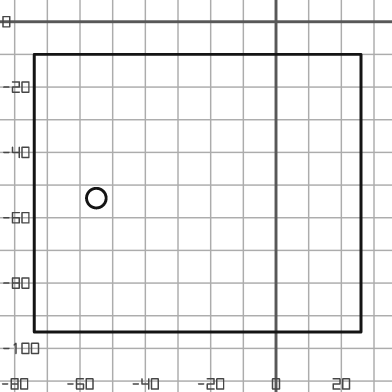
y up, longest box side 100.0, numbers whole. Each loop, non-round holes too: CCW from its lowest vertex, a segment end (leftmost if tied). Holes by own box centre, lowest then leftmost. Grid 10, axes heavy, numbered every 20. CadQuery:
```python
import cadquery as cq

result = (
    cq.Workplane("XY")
    .moveTo(-74.0, -95.0)
    .lineTo(26.0, -95.0)
    .lineTo(26.0, -10.0)
    .lineTo(-74.0, -10.0)
    .close()
    .moveTo(-55.0, -54.0)
    .circle(3.0)
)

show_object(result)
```